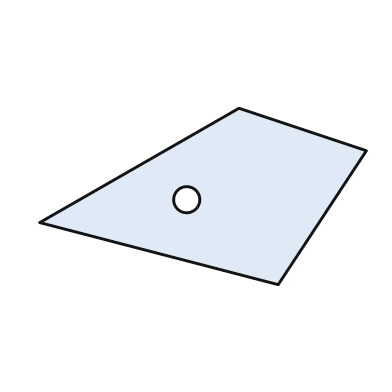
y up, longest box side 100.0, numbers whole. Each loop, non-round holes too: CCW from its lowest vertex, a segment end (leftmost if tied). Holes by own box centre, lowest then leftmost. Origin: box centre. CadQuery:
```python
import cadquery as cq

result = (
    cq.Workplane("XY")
    .moveTo(23.0, -27.0)
    .lineTo(50.0, 14.0)
    .lineTo(11.0, 27.0)
    .lineTo(-50.0, -8.0)
    .close()
    .moveTo(-5.0, -1.0)
    .circle(4.0)
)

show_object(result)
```